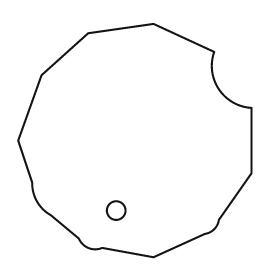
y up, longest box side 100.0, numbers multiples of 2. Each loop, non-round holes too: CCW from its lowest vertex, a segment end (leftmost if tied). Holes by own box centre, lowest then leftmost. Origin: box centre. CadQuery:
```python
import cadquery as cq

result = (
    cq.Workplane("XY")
    .moveTo(8.0, -50.0)
    .lineTo(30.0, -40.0)
    .threePointArc((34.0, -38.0), (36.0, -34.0))
    .lineTo(50.0, -14.0)
    .lineTo(50.0, 14.0)
    .threePointArc((36.0, 22.0), (34.0, 38.0))
    .lineTo(8.0, 50.0)
    .lineTo(-20.0, 46.0)
    .lineTo(-40.0, 28.0)
    .lineTo(-50.0, 0.0)
    .lineTo(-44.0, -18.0)
    .threePointArc((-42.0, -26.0), (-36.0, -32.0))
    .lineTo(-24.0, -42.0)
    .threePointArc((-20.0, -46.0), (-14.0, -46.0))
    .close()
    .moveTo(-8.0, -30.0)
    .circle(4.0)
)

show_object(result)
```